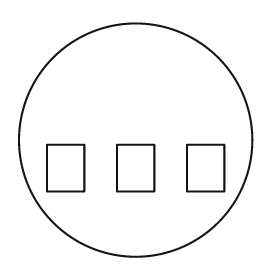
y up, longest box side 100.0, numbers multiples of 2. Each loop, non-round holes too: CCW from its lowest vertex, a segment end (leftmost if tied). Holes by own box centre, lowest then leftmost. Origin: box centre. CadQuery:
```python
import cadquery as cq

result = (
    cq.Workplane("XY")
    .moveTo(0.0, 0.0)
    .circle(50.0)
    .moveTo(-38.0, -22.0)
    .lineTo(-22.0, -22.0)
    .lineTo(-22.0, -2.0)
    .lineTo(-38.0, -2.0)
    .close()
    .moveTo(-8.0, -22.0)
    .lineTo(8.0, -22.0)
    .lineTo(8.0, -2.0)
    .lineTo(-8.0, -2.0)
    .close()
    .moveTo(22.0, -22.0)
    .lineTo(38.0, -22.0)
    .lineTo(38.0, -2.0)
    .lineTo(22.0, -2.0)
    .close()
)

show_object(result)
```